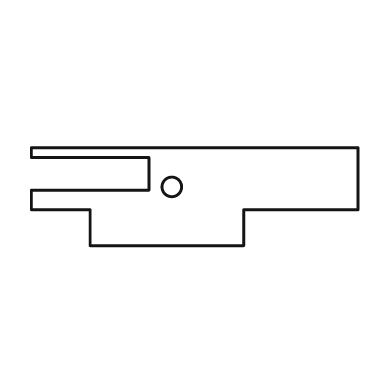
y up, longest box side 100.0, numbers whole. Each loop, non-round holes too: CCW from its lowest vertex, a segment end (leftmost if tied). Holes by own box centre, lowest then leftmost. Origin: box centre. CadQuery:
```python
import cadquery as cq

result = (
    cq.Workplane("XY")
    .moveTo(-32.0, -15.0)
    .lineTo(15.0, -15.0)
    .lineTo(15.0, -4.0)
    .lineTo(50.0, -4.0)
    .lineTo(50.0, 15.0)
    .lineTo(-50.0, 15.0)
    .lineTo(-50.0, 12.0)
    .lineTo(-14.0, 12.0)
    .lineTo(-14.0, 2.0)
    .lineTo(-50.0, 2.0)
    .lineTo(-50.0, -4.0)
    .lineTo(-32.0, -4.0)
    .close()
    .moveTo(-7.0, 3.0)
    .circle(3.0)
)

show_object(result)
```